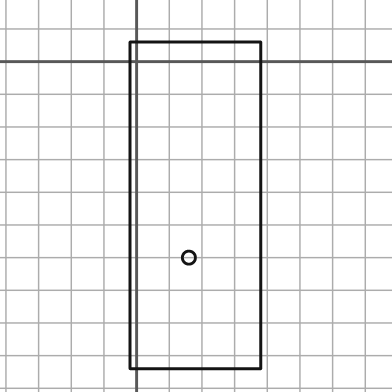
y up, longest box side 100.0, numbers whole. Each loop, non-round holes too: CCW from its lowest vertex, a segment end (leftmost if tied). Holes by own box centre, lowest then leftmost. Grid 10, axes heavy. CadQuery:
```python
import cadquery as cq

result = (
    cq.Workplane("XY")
    .moveTo(-2.0, -94.0)
    .lineTo(38.0, -94.0)
    .lineTo(38.0, 6.0)
    .lineTo(-2.0, 6.0)
    .close()
    .moveTo(16.0, -60.0)
    .circle(2.0)
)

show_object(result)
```